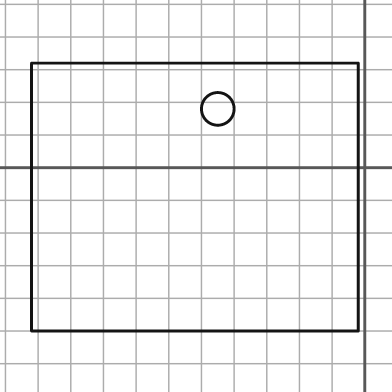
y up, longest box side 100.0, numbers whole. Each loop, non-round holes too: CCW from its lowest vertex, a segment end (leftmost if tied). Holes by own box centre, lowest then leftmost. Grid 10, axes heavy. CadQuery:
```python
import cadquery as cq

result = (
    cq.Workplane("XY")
    .moveTo(-102.0, -50.0)
    .lineTo(-2.0, -50.0)
    .lineTo(-2.0, 32.0)
    .lineTo(-102.0, 32.0)
    .close()
    .moveTo(-45.0, 18.0)
    .circle(5.0)
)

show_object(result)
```